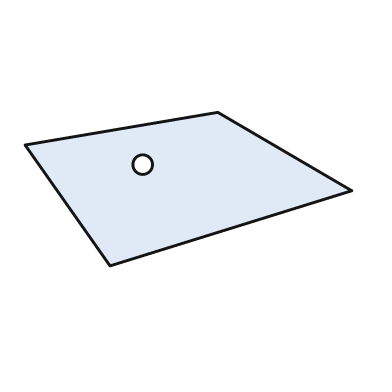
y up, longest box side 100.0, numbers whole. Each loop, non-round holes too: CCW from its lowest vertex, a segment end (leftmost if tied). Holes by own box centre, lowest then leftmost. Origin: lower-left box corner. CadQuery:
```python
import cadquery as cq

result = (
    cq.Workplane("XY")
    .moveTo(26.0, 0.0)
    .lineTo(100.0, 23.0)
    .lineTo(59.0, 47.0)
    .lineTo(0.0, 37.0)
    .close()
    .moveTo(36.0, 31.0)
    .circle(3.0)
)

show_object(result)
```